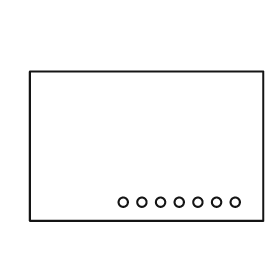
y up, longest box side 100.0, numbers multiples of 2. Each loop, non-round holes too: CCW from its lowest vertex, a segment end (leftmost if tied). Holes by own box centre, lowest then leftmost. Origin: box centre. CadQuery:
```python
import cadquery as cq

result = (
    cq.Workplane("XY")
    .moveTo(-50.0, -32.0)
    .lineTo(50.0, -32.0)
    .lineTo(50.0, 32.0)
    .lineTo(-50.0, 32.0)
    .close()
    .moveTo(-10.0, -24.0)
    .circle(2.0)
    .moveTo(-2.0, -24.0)
    .circle(2.0)
    .moveTo(6.0, -24.0)
    .circle(2.0)
    .moveTo(14.0, -24.0)
    .circle(2.0)
    .moveTo(22.0, -24.0)
    .circle(2.0)
    .moveTo(30.0, -24.0)
    .circle(2.0)
    .moveTo(38.0, -24.0)
    .circle(2.0)
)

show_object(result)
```